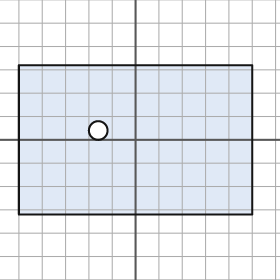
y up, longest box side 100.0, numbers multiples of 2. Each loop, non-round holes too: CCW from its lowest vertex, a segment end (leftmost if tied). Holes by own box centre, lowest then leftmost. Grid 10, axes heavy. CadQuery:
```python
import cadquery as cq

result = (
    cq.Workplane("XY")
    .moveTo(-50.0, -32.0)
    .lineTo(50.0, -32.0)
    .lineTo(50.0, 32.0)
    .lineTo(-50.0, 32.0)
    .close()
    .moveTo(-16.0, 4.0)
    .circle(4.0)
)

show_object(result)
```